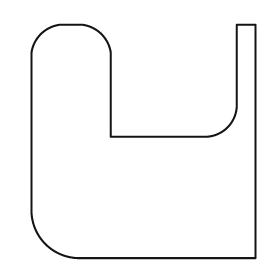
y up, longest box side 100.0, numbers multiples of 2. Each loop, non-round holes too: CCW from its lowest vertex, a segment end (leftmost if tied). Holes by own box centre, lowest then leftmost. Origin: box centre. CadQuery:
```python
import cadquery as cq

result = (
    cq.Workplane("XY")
    .moveTo(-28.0, -50.0)
    .lineTo(48.0, -50.0)
    .lineTo(48.0, 50.0)
    .lineTo(40.0, 50.0)
    .lineTo(40.0, 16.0)
    .threePointArc((36.0, 6.0), (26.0, 2.0))
    .lineTo(-14.0, 2.0)
    .lineTo(-14.0, 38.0)
    .threePointArc((-18.0, 46.0), (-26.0, 50.0))
    .lineTo(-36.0, 50.0)
    .threePointArc((-44.0, 46.0), (-48.0, 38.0))
    .lineTo(-48.0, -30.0)
    .threePointArc((-42.0, -44.0), (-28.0, -50.0))
    .close()
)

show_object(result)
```